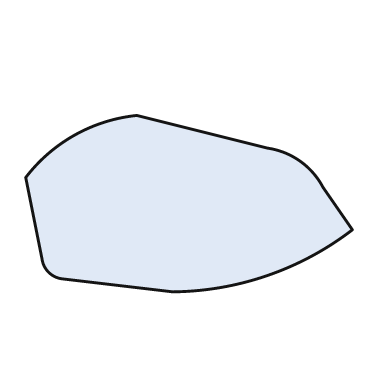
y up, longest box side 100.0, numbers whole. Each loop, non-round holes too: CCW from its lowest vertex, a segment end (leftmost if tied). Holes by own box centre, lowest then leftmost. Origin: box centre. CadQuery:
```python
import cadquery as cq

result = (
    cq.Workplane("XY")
    .moveTo(-5.0, -27.0)
    .threePointArc((24.0, -22.0), (50.0, -8.0))
    .lineTo(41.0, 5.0)
    .threePointArc((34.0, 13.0), (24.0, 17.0))
    .lineTo(-16.0, 27.0)
    .threePointArc((-35.0, 21.0), (-50.0, 8.0))
    .lineTo(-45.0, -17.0)
    .threePointArc((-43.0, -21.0), (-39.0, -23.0))
    .close()
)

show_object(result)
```